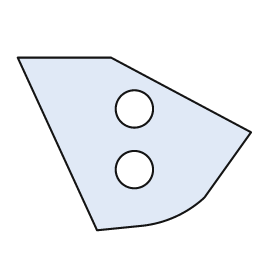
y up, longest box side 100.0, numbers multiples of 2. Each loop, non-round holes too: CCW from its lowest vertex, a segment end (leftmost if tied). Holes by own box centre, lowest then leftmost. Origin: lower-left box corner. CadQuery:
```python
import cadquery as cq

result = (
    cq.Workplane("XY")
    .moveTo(34.0, 0.0)
    .lineTo(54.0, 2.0)
    .threePointArc((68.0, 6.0), (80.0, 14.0))
    .lineTo(100.0, 42.0)
    .lineTo(40.0, 74.0)
    .lineTo(0.0, 74.0)
    .close()
    .moveTo(50.0, 26.0)
    .circle(8.0)
    .moveTo(50.0, 52.0)
    .circle(8.0)
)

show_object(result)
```